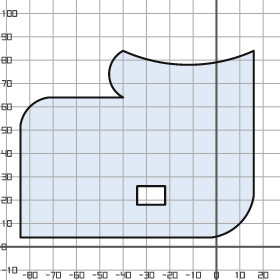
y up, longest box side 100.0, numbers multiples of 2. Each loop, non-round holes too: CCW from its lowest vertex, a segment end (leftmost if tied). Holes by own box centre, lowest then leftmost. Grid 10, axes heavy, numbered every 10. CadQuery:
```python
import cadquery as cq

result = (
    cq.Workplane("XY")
    .moveTo(-84.0, 4.0)
    .lineTo(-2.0, 4.0)
    .threePointArc((10.0, 10.0), (16.0, 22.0))
    .lineTo(16.0, 84.0)
    .threePointArc((-12.0, 78.0), (-40.0, 84.0))
    .threePointArc((-46.0, 74.0), (-40.0, 64.0))
    .lineTo(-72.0, 64.0)
    .threePointArc((-80.0, 60.0), (-84.0, 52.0))
    .close()
    .moveTo(-34.0, 18.0)
    .lineTo(-22.0, 18.0)
    .lineTo(-22.0, 26.0)
    .lineTo(-34.0, 26.0)
    .close()
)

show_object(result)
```